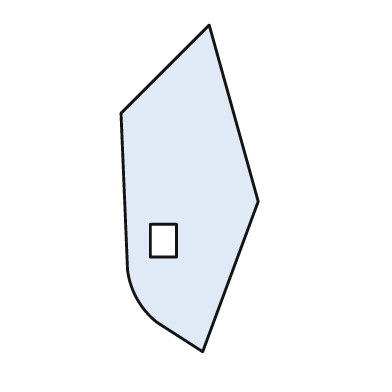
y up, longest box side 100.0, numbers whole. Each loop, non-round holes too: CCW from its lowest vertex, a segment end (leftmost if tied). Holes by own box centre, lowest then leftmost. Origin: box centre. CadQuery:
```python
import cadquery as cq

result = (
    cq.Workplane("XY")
    .moveTo(4.0, -50.0)
    .lineTo(21.0, -4.0)
    .lineTo(6.0, 50.0)
    .lineTo(-21.0, 23.0)
    .lineTo(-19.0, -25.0)
    .threePointArc((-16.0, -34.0), (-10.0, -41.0))
    .close()
    .moveTo(-12.0, -21.0)
    .lineTo(-4.0, -21.0)
    .lineTo(-4.0, -11.0)
    .lineTo(-12.0, -11.0)
    .close()
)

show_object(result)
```